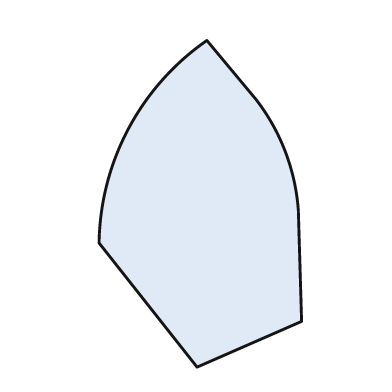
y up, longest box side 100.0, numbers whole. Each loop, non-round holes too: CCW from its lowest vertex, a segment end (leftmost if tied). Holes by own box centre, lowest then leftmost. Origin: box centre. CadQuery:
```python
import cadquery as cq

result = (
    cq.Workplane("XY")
    .moveTo(-1.0, -50.0)
    .lineTo(31.0, -36.0)
    .lineTo(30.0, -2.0)
    .threePointArc((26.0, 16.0), (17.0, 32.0))
    .lineTo(2.0, 50.0)
    .threePointArc((-22.0, 23.0), (-31.0, -12.0))
    .close()
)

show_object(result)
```